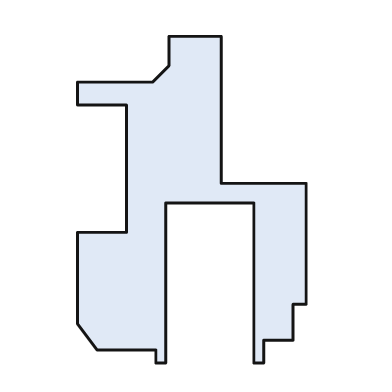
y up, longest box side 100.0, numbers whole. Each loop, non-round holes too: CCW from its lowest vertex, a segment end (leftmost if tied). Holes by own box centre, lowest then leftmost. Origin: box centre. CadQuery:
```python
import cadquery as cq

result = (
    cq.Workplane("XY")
    .moveTo(-11.0, -50.0)
    .lineTo(-8.0, -50.0)
    .lineTo(-8.0, -1.0)
    .lineTo(19.0, -1.0)
    .lineTo(19.0, -50.0)
    .lineTo(22.0, -50.0)
    .lineTo(22.0, -43.0)
    .lineTo(31.0, -43.0)
    .lineTo(31.0, -32.0)
    .lineTo(35.0, -32.0)
    .lineTo(35.0, 5.0)
    .lineTo(9.0, 5.0)
    .lineTo(9.0, 50.0)
    .lineTo(-7.0, 50.0)
    .lineTo(-7.0, 41.0)
    .lineTo(-12.0, 36.0)
    .lineTo(-35.0, 36.0)
    .lineTo(-35.0, 29.0)
    .lineTo(-20.0, 29.0)
    .lineTo(-20.0, -10.0)
    .lineTo(-35.0, -10.0)
    .lineTo(-35.0, -38.0)
    .lineTo(-29.0, -46.0)
    .lineTo(-11.0, -46.0)
    .close()
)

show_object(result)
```